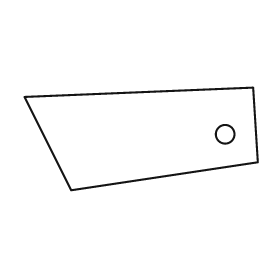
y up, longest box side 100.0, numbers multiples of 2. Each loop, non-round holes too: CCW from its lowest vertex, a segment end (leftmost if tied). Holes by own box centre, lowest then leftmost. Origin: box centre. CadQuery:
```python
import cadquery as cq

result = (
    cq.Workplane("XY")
    .moveTo(-30.0, -22.0)
    .lineTo(50.0, -10.0)
    .lineTo(48.0, 22.0)
    .lineTo(-50.0, 18.0)
    .close()
    .moveTo(36.0, 2.0)
    .circle(4.0)
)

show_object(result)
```